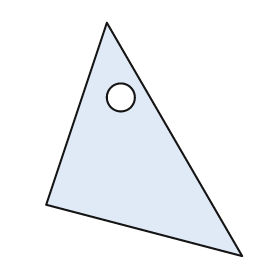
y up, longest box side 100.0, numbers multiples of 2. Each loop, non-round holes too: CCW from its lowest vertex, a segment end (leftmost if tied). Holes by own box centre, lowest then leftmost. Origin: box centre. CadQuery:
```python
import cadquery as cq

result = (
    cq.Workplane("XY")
    .moveTo(42.0, -50.0)
    .lineTo(-16.0, 50.0)
    .lineTo(-42.0, -28.0)
    .close()
    .moveTo(-10.0, 18.0)
    .circle(6.0)
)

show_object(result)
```